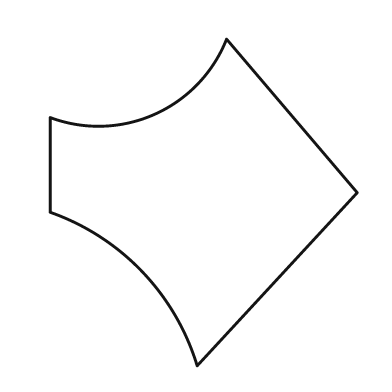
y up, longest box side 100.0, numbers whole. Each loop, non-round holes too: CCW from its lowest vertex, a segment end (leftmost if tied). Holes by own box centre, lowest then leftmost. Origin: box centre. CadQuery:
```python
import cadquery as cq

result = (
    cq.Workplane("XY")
    .moveTo(-2.0, -50.0)
    .lineTo(47.0, 3.0)
    .lineTo(7.0, 50.0)
    .threePointArc((-15.0, 27.0), (-47.0, 26.0))
    .lineTo(-47.0, -3.0)
    .threePointArc((-19.0, -21.0), (-2.0, -50.0))
    .close()
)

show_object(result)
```